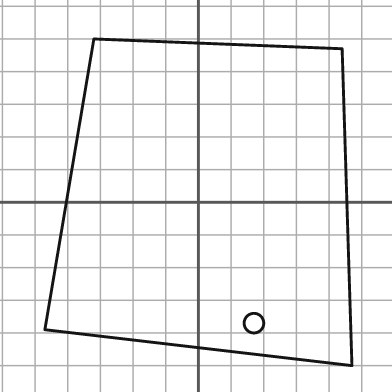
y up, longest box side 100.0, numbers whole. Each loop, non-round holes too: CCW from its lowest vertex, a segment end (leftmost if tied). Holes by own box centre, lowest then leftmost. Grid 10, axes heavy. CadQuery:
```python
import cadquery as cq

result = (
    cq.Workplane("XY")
    .moveTo(47.0, -50.0)
    .lineTo(44.0, 47.0)
    .lineTo(-32.0, 50.0)
    .lineTo(-47.0, -39.0)
    .close()
    .moveTo(17.0, -37.0)
    .circle(3.0)
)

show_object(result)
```